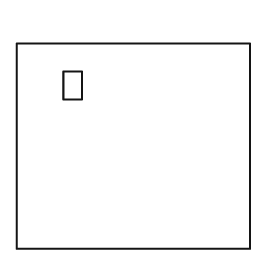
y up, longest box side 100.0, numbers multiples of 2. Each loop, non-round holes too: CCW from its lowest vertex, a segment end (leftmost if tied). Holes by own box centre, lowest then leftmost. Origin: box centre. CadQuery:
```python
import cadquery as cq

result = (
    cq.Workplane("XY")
    .moveTo(-50.0, -44.0)
    .lineTo(50.0, -44.0)
    .lineTo(50.0, 44.0)
    .lineTo(-50.0, 44.0)
    .close()
    .moveTo(-30.0, 20.0)
    .lineTo(-22.0, 20.0)
    .lineTo(-22.0, 32.0)
    .lineTo(-30.0, 32.0)
    .close()
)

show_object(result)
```